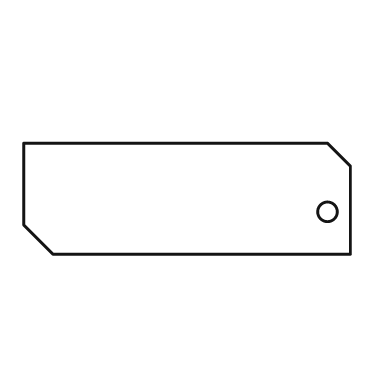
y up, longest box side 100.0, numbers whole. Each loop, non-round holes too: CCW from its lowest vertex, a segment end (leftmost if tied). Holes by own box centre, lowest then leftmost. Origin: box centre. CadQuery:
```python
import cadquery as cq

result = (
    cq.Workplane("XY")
    .moveTo(-41.0, -17.0)
    .lineTo(50.0, -17.0)
    .lineTo(50.0, 10.0)
    .lineTo(43.0, 17.0)
    .lineTo(-50.0, 17.0)
    .lineTo(-50.0, -8.0)
    .close()
    .moveTo(43.0, -4.0)
    .circle(3.0)
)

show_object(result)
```